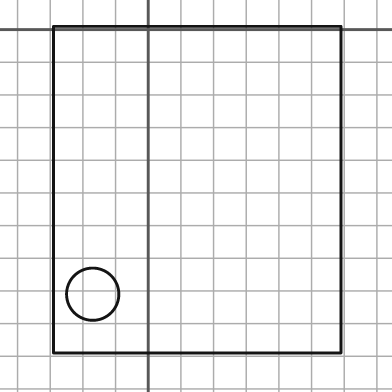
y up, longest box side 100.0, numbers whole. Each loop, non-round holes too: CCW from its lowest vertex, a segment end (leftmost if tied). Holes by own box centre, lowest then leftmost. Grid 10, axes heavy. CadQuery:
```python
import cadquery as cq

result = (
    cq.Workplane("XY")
    .moveTo(-29.0, -99.0)
    .lineTo(59.0, -99.0)
    .lineTo(59.0, 1.0)
    .lineTo(-29.0, 1.0)
    .close()
    .moveTo(-17.0, -81.0)
    .circle(8.0)
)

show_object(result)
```